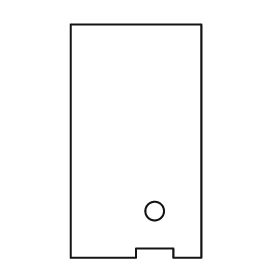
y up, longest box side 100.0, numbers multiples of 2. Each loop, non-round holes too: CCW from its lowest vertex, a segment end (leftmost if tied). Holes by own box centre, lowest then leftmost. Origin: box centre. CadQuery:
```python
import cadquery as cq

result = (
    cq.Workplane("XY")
    .moveTo(-28.0, -50.0)
    .lineTo(0.0, -50.0)
    .lineTo(0.0, -46.0)
    .lineTo(16.0, -46.0)
    .lineTo(16.0, -50.0)
    .lineTo(28.0, -50.0)
    .lineTo(28.0, 50.0)
    .lineTo(-28.0, 50.0)
    .close()
    .moveTo(8.0, -30.0)
    .circle(4.0)
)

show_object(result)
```